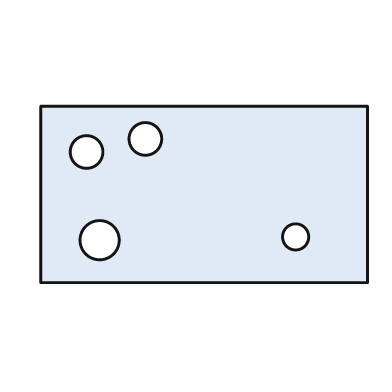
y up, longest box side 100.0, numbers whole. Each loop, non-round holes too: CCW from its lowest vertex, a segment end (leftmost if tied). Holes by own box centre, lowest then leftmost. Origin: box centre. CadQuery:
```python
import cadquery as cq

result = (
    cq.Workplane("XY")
    .moveTo(-50.0, -27.0)
    .lineTo(50.0, -27.0)
    .lineTo(50.0, 27.0)
    .lineTo(-50.0, 27.0)
    .close()
    .moveTo(-32.0, -14.0)
    .circle(6.0)
    .moveTo(28.0, -13.0)
    .circle(4.0)
    .moveTo(-36.0, 13.0)
    .circle(5.0)
    .moveTo(-18.0, 17.0)
    .circle(5.0)
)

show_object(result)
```